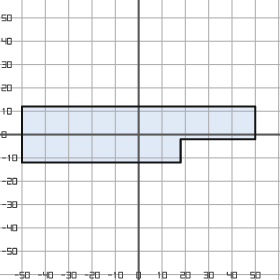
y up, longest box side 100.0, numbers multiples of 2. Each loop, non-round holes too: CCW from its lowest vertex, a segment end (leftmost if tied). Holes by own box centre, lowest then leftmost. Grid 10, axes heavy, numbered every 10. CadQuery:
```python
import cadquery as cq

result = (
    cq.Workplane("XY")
    .moveTo(-50.0, -12.0)
    .lineTo(18.0, -12.0)
    .lineTo(18.0, -2.0)
    .lineTo(50.0, -2.0)
    .lineTo(50.0, 12.0)
    .lineTo(-50.0, 12.0)
    .close()
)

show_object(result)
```